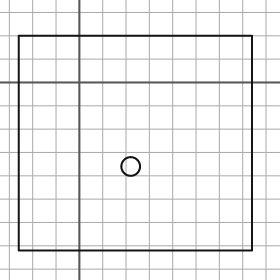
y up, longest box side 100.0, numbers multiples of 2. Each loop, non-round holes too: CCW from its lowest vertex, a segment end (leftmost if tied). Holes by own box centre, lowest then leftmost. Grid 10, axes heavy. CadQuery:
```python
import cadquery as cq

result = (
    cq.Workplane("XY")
    .moveTo(-26.0, -72.0)
    .lineTo(74.0, -72.0)
    .lineTo(74.0, 20.0)
    .lineTo(-26.0, 20.0)
    .close()
    .moveTo(22.0, -36.0)
    .circle(4.0)
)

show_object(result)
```